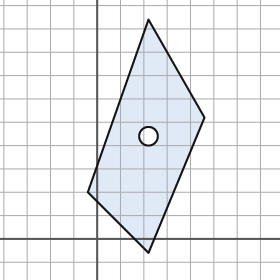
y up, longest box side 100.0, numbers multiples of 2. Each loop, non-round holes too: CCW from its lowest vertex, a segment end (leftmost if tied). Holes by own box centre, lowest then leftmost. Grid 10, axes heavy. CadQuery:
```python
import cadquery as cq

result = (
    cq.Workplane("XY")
    .moveTo(22.0, -6.0)
    .lineTo(46.0, 52.0)
    .lineTo(22.0, 94.0)
    .lineTo(-4.0, 20.0)
    .close()
    .moveTo(22.0, 44.0)
    .circle(4.0)
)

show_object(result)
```